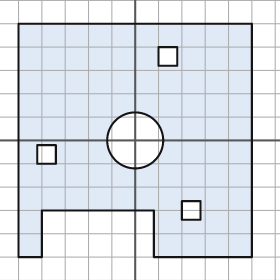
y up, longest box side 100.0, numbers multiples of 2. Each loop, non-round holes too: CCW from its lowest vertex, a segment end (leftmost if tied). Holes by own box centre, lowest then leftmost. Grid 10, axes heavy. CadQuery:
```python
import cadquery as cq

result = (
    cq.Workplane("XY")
    .moveTo(-50.0, -50.0)
    .lineTo(-40.0, -50.0)
    .lineTo(-40.0, -30.0)
    .lineTo(8.0, -30.0)
    .lineTo(8.0, -50.0)
    .lineTo(50.0, -50.0)
    .lineTo(50.0, 50.0)
    .lineTo(-50.0, 50.0)
    .close()
    .moveTo(20.0, -34.0)
    .lineTo(28.0, -34.0)
    .lineTo(28.0, -26.0)
    .lineTo(20.0, -26.0)
    .close()
    .moveTo(-42.0, -10.0)
    .lineTo(-34.0, -10.0)
    .lineTo(-34.0, -2.0)
    .lineTo(-42.0, -2.0)
    .close()
    .moveTo(0.0, 0.0)
    .circle(12.0)
    .moveTo(10.0, 32.0)
    .lineTo(18.0, 32.0)
    .lineTo(18.0, 40.0)
    .lineTo(10.0, 40.0)
    .close()
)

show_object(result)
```